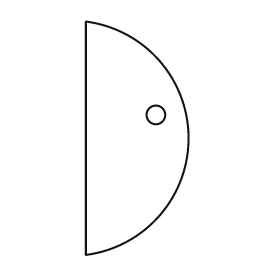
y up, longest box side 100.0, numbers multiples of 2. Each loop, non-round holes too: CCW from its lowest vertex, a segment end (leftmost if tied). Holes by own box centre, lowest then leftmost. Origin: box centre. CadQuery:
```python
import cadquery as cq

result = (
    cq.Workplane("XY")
    .moveTo(-22.0, -50.0)
    .threePointArc((22.0, 0.0), (-22.0, 50.0))
    .close()
    .moveTo(8.0, 10.0)
    .circle(4.0)
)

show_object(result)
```